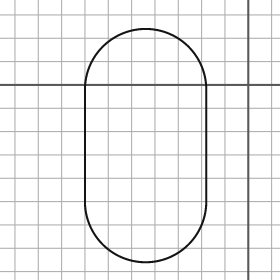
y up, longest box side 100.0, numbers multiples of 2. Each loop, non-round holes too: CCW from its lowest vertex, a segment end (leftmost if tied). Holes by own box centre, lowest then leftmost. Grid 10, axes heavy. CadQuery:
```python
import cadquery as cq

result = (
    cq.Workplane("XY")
    .moveTo(-70.0, -50.0)
    .threePointArc((-44.0, -76.0), (-18.0, -50.0))
    .lineTo(-18.0, -2.0)
    .threePointArc((-44.0, 24.0), (-70.0, -2.0))
    .close()
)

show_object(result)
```